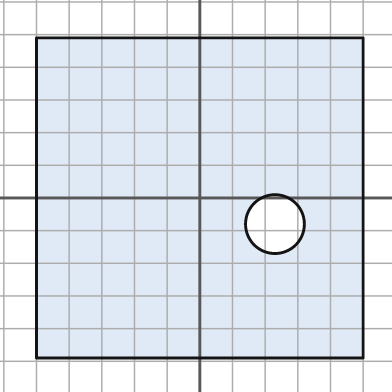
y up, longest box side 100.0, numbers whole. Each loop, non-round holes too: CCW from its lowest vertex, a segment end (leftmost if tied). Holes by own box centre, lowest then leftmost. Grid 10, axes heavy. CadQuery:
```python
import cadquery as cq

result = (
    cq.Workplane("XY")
    .moveTo(-50.0, -49.0)
    .lineTo(50.0, -49.0)
    .lineTo(50.0, 49.0)
    .lineTo(-50.0, 49.0)
    .close()
    .moveTo(23.0, -8.0)
    .circle(9.0)
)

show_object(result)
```